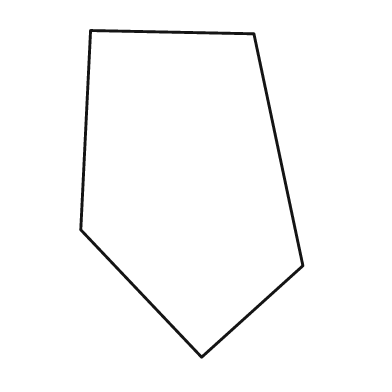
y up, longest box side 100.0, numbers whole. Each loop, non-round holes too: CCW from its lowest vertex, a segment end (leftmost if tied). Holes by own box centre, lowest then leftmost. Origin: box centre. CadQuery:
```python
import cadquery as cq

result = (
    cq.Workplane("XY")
    .moveTo(3.0, -50.0)
    .lineTo(34.0, -22.0)
    .lineTo(19.0, 49.0)
    .lineTo(-31.0, 50.0)
    .lineTo(-34.0, -11.0)
    .close()
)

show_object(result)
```